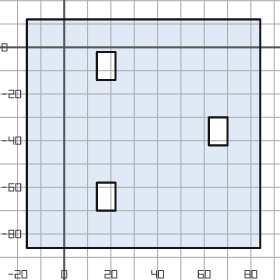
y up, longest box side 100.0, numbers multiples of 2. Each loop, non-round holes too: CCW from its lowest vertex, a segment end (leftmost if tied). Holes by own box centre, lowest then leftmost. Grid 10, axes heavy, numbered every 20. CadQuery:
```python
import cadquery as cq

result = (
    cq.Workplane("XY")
    .moveTo(-16.0, -86.0)
    .lineTo(84.0, -86.0)
    .lineTo(84.0, 12.0)
    .lineTo(-16.0, 12.0)
    .close()
    .moveTo(14.0, -70.0)
    .lineTo(22.0, -70.0)
    .lineTo(22.0, -58.0)
    .lineTo(14.0, -58.0)
    .close()
    .moveTo(62.0, -42.0)
    .lineTo(70.0, -42.0)
    .lineTo(70.0, -30.0)
    .lineTo(62.0, -30.0)
    .close()
    .moveTo(14.0, -14.0)
    .lineTo(22.0, -14.0)
    .lineTo(22.0, -2.0)
    .lineTo(14.0, -2.0)
    .close()
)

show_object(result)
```